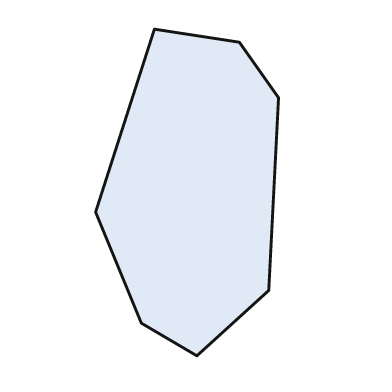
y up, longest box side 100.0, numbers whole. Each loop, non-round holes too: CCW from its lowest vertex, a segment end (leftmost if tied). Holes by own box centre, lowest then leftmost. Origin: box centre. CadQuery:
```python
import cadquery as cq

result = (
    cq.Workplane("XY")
    .moveTo(3.0, -50.0)
    .lineTo(25.0, -30.0)
    .lineTo(28.0, 29.0)
    .lineTo(16.0, 46.0)
    .lineTo(-10.0, 50.0)
    .lineTo(-28.0, -6.0)
    .lineTo(-14.0, -40.0)
    .close()
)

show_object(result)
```